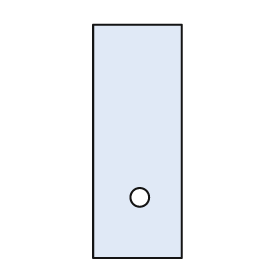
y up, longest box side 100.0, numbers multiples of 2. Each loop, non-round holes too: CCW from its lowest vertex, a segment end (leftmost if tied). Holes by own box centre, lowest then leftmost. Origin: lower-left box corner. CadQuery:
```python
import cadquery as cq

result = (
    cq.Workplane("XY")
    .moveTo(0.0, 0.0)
    .lineTo(38.0, 0.0)
    .lineTo(38.0, 100.0)
    .lineTo(0.0, 100.0)
    .close()
    .moveTo(20.0, 26.0)
    .circle(4.0)
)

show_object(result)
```